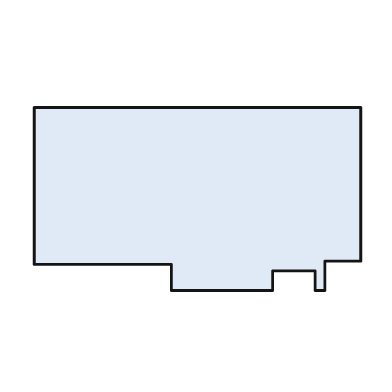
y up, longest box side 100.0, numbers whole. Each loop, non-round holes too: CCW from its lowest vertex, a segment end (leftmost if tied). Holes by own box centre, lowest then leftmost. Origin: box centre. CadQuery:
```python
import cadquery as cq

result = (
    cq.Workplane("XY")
    .moveTo(-8.0, -28.0)
    .lineTo(23.0, -28.0)
    .lineTo(23.0, -22.0)
    .lineTo(36.0, -22.0)
    .lineTo(36.0, -28.0)
    .lineTo(39.0, -28.0)
    .lineTo(39.0, -19.0)
    .lineTo(50.0, -19.0)
    .lineTo(50.0, 28.0)
    .lineTo(-50.0, 28.0)
    .lineTo(-50.0, -20.0)
    .lineTo(-8.0, -20.0)
    .close()
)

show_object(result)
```